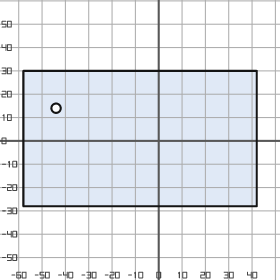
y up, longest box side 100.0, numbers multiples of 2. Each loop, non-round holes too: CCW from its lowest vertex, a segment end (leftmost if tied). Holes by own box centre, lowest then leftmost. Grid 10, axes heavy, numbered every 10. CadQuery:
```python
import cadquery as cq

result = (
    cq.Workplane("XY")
    .moveTo(-58.0, -28.0)
    .lineTo(42.0, -28.0)
    .lineTo(42.0, 30.0)
    .lineTo(-58.0, 30.0)
    .close()
    .moveTo(-44.0, 14.0)
    .circle(2.0)
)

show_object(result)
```